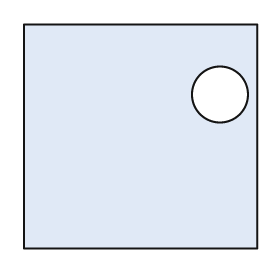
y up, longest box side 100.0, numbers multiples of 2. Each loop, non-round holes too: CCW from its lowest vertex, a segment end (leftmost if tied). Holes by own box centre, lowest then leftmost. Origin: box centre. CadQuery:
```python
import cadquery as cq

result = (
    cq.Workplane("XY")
    .moveTo(-50.0, -48.0)
    .lineTo(50.0, -48.0)
    .lineTo(50.0, 48.0)
    .lineTo(-50.0, 48.0)
    .close()
    .moveTo(34.0, 18.0)
    .circle(12.0)
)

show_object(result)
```